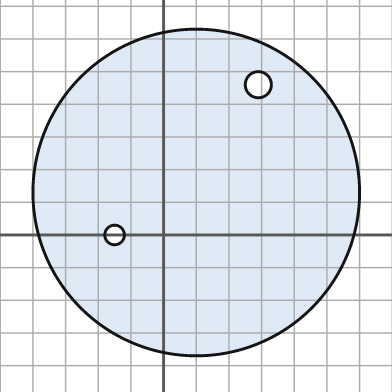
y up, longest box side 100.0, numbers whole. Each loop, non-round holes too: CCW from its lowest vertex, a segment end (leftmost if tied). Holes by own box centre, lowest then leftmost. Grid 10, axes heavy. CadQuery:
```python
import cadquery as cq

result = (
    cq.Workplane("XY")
    .moveTo(10.0, 13.0)
    .circle(50.0)
    .moveTo(-15.0, 0.0)
    .circle(3.0)
    .moveTo(29.0, 46.0)
    .circle(4.0)
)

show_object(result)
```